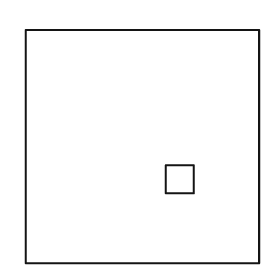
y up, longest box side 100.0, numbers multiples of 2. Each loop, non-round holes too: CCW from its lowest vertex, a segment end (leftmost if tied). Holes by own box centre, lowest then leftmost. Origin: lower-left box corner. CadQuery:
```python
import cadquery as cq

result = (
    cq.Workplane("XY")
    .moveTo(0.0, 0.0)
    .lineTo(100.0, 0.0)
    .lineTo(100.0, 100.0)
    .lineTo(0.0, 100.0)
    .close()
    .moveTo(60.0, 30.0)
    .lineTo(72.0, 30.0)
    .lineTo(72.0, 42.0)
    .lineTo(60.0, 42.0)
    .close()
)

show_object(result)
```